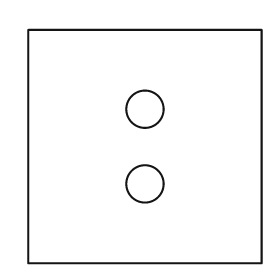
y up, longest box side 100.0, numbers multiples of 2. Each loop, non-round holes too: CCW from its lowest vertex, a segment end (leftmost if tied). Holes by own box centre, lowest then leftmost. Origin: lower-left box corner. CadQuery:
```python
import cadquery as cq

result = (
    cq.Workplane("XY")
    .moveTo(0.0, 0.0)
    .lineTo(100.0, 0.0)
    .lineTo(100.0, 100.0)
    .lineTo(0.0, 100.0)
    .close()
    .moveTo(50.0, 34.0)
    .circle(8.0)
    .moveTo(50.0, 66.0)
    .circle(8.0)
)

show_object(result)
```